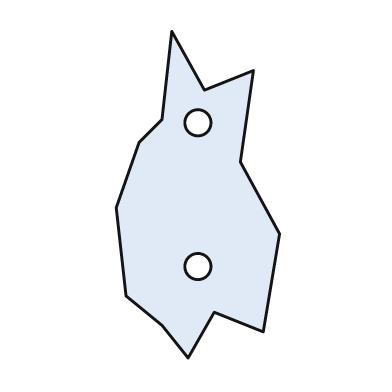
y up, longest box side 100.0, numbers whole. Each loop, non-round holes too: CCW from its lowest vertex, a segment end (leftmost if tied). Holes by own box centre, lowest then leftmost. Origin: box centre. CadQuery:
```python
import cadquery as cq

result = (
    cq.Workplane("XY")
    .moveTo(-3.0, -50.0)
    .lineTo(5.0, -36.0)
    .lineTo(20.0, -42.0)
    .lineTo(25.0, -12.0)
    .lineTo(13.0, 10.0)
    .lineTo(17.0, 38.0)
    .lineTo(2.0, 32.0)
    .lineTo(-8.0, 50.0)
    .lineTo(-11.0, 23.0)
    .lineTo(-18.0, 16.0)
    .lineTo(-25.0, -4.0)
    .lineTo(-22.0, -31.0)
    .lineTo(-11.0, -40.0)
    .close()
    .moveTo(0.0, -22.0)
    .circle(4.0)
    .moveTo(0.0, 22.0)
    .circle(4.0)
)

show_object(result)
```